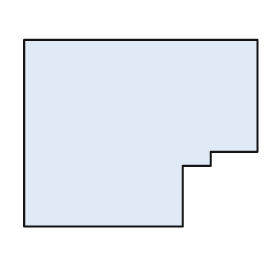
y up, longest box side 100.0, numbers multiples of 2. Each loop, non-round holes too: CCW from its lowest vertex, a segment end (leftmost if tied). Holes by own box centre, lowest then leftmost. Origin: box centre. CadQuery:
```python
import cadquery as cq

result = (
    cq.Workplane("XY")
    .moveTo(-50.0, -40.0)
    .lineTo(18.0, -40.0)
    .lineTo(18.0, -14.0)
    .lineTo(30.0, -14.0)
    .lineTo(30.0, -8.0)
    .lineTo(50.0, -8.0)
    .lineTo(50.0, 40.0)
    .lineTo(-50.0, 40.0)
    .close()
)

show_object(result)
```